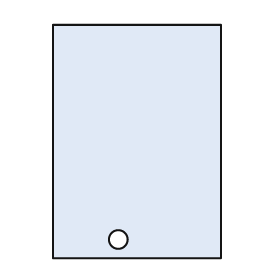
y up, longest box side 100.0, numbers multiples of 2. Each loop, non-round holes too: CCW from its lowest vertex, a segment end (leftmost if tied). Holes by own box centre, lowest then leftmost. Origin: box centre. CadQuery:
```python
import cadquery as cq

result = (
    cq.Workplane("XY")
    .moveTo(-36.0, -50.0)
    .lineTo(36.0, -50.0)
    .lineTo(36.0, 50.0)
    .lineTo(-36.0, 50.0)
    .close()
    .moveTo(-8.0, -42.0)
    .circle(4.0)
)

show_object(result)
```